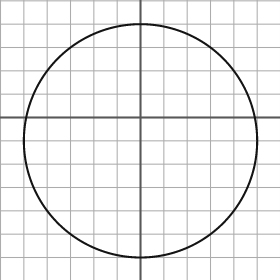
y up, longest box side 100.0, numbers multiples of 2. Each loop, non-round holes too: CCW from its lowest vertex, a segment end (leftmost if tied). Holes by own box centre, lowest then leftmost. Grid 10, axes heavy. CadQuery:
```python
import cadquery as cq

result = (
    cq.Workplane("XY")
    .moveTo(0.0, -10.0)
    .circle(50.0)
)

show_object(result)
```